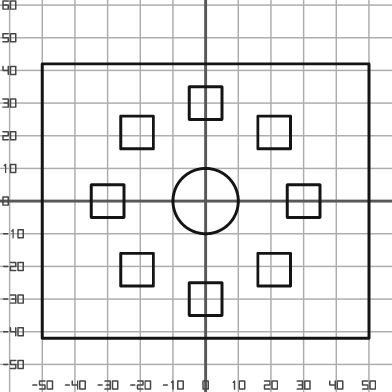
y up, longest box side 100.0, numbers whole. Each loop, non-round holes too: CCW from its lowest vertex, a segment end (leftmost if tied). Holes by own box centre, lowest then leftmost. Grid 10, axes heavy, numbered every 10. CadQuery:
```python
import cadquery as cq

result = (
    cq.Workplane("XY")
    .moveTo(-50.0, -42.0)
    .lineTo(50.0, -42.0)
    .lineTo(50.0, 42.0)
    .lineTo(-50.0, 42.0)
    .close()
    .moveTo(-5.0, -35.0)
    .lineTo(5.0, -35.0)
    .lineTo(5.0, -25.0)
    .lineTo(-5.0, -25.0)
    .close()
    .moveTo(-26.0, -26.0)
    .lineTo(-16.0, -26.0)
    .lineTo(-16.0, -16.0)
    .lineTo(-26.0, -16.0)
    .close()
    .moveTo(16.0, -26.0)
    .lineTo(26.0, -26.0)
    .lineTo(26.0, -16.0)
    .lineTo(16.0, -16.0)
    .close()
    .moveTo(-35.0, -5.0)
    .lineTo(-25.0, -5.0)
    .lineTo(-25.0, 5.0)
    .lineTo(-35.0, 5.0)
    .close()
    .moveTo(0.0, 0.0)
    .circle(10.0)
    .moveTo(25.0, -5.0)
    .lineTo(35.0, -5.0)
    .lineTo(35.0, 5.0)
    .lineTo(25.0, 5.0)
    .close()
    .moveTo(-26.0, 16.0)
    .lineTo(-16.0, 16.0)
    .lineTo(-16.0, 26.0)
    .lineTo(-26.0, 26.0)
    .close()
    .moveTo(16.0, 16.0)
    .lineTo(26.0, 16.0)
    .lineTo(26.0, 26.0)
    .lineTo(16.0, 26.0)
    .close()
    .moveTo(-5.0, 25.0)
    .lineTo(5.0, 25.0)
    .lineTo(5.0, 35.0)
    .lineTo(-5.0, 35.0)
    .close()
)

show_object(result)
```